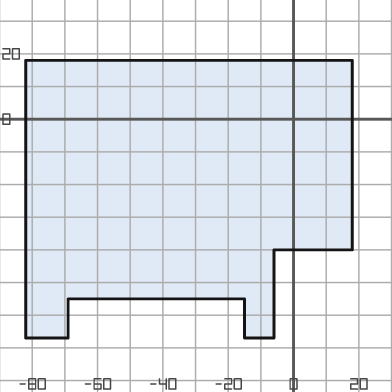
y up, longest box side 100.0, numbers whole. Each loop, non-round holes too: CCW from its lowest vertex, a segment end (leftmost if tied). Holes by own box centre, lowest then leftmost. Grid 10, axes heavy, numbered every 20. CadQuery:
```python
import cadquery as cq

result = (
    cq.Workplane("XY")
    .moveTo(-82.0, -67.0)
    .lineTo(-69.0, -67.0)
    .lineTo(-69.0, -55.0)
    .lineTo(-15.0, -55.0)
    .lineTo(-15.0, -67.0)
    .lineTo(-6.0, -67.0)
    .lineTo(-6.0, -40.0)
    .lineTo(18.0, -40.0)
    .lineTo(18.0, 18.0)
    .lineTo(-82.0, 18.0)
    .close()
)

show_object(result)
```